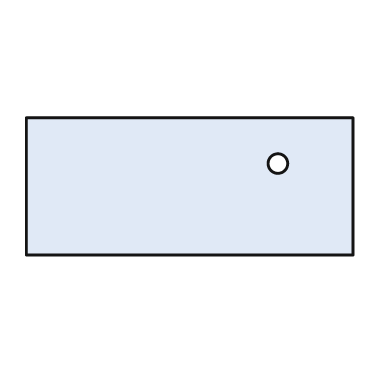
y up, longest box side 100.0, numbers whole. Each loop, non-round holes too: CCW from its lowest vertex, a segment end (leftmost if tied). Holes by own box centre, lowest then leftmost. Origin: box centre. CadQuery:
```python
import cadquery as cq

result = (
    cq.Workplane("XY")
    .moveTo(-50.0, -21.0)
    .lineTo(50.0, -21.0)
    .lineTo(50.0, 21.0)
    .lineTo(-50.0, 21.0)
    .close()
    .moveTo(27.0, 7.0)
    .circle(3.0)
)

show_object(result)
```